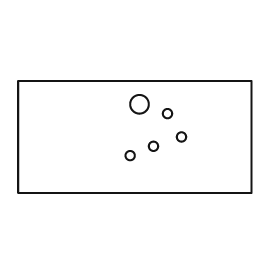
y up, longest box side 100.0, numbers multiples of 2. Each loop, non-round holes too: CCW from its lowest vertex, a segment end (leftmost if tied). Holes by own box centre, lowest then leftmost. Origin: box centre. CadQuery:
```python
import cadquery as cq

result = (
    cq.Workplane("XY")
    .moveTo(-50.0, -24.0)
    .lineTo(50.0, -24.0)
    .lineTo(50.0, 24.0)
    .lineTo(-50.0, 24.0)
    .close()
    .moveTo(-2.0, -8.0)
    .circle(2.0)
    .moveTo(8.0, -4.0)
    .circle(2.0)
    .moveTo(20.0, 0.0)
    .circle(2.0)
    .moveTo(14.0, 10.0)
    .circle(2.0)
    .moveTo(2.0, 14.0)
    .circle(4.0)
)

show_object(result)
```